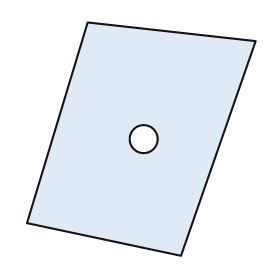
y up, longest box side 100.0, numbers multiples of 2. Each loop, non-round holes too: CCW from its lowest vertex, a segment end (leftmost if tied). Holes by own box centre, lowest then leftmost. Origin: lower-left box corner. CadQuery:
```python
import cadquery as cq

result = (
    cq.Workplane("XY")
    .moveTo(66.0, 0.0)
    .lineTo(98.0, 92.0)
    .lineTo(26.0, 100.0)
    .lineTo(0.0, 14.0)
    .close()
    .moveTo(50.0, 50.0)
    .circle(6.0)
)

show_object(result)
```